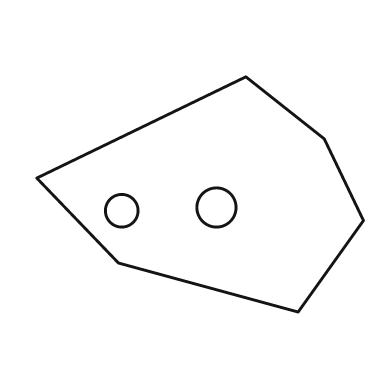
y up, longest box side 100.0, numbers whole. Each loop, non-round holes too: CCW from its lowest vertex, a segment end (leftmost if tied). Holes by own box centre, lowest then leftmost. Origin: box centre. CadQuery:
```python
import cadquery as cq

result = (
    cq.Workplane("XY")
    .moveTo(30.0, -36.0)
    .lineTo(50.0, -8.0)
    .lineTo(38.0, 17.0)
    .lineTo(14.0, 36.0)
    .lineTo(-50.0, 5.0)
    .lineTo(-25.0, -21.0)
    .close()
    .moveTo(-24.0, -5.0)
    .circle(5.0)
    .moveTo(5.0, -4.0)
    .circle(6.0)
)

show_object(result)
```